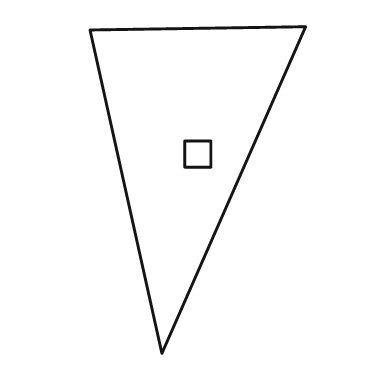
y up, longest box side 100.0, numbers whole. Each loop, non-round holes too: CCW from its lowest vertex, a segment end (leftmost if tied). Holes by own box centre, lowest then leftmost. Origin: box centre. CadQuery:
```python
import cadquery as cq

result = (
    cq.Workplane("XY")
    .moveTo(-11.0, -50.0)
    .lineTo(33.0, 50.0)
    .lineTo(-33.0, 49.0)
    .close()
    .moveTo(-4.0, 7.0)
    .lineTo(4.0, 7.0)
    .lineTo(4.0, 15.0)
    .lineTo(-4.0, 15.0)
    .close()
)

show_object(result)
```